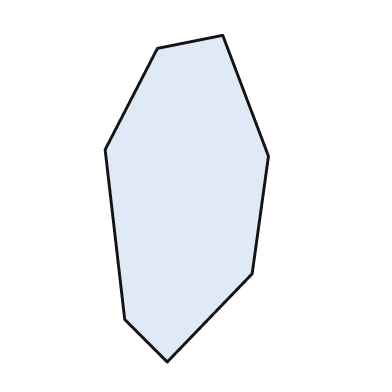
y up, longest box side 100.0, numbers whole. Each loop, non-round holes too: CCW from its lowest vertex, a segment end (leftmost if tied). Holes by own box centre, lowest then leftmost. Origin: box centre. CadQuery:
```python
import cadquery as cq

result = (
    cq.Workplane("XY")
    .moveTo(-6.0, -50.0)
    .lineTo(20.0, -23.0)
    .lineTo(25.0, 13.0)
    .lineTo(11.0, 50.0)
    .lineTo(-9.0, 46.0)
    .lineTo(-25.0, 15.0)
    .lineTo(-19.0, -37.0)
    .close()
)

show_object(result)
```